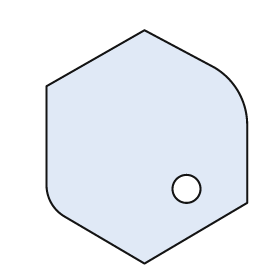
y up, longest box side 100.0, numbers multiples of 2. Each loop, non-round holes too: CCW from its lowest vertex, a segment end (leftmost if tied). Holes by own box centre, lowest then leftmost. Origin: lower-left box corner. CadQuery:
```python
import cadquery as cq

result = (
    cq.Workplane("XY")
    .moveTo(42.0, 0.0)
    .lineTo(86.0, 26.0)
    .lineTo(86.0, 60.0)
    .threePointArc((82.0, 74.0), (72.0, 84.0))
    .lineTo(42.0, 100.0)
    .lineTo(0.0, 76.0)
    .lineTo(0.0, 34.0)
    .threePointArc((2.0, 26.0), (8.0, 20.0))
    .close()
    .moveTo(60.0, 32.0)
    .circle(6.0)
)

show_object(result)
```